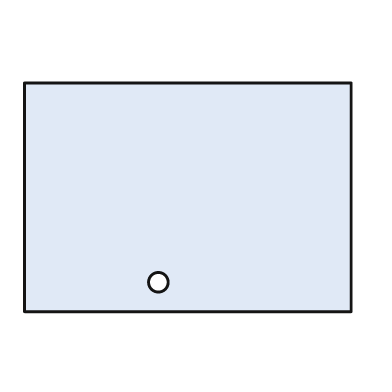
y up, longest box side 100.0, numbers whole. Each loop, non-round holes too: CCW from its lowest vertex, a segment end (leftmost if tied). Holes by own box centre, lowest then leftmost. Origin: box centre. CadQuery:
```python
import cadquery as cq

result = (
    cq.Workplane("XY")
    .moveTo(-50.0, -35.0)
    .lineTo(50.0, -35.0)
    .lineTo(50.0, 35.0)
    .lineTo(-50.0, 35.0)
    .close()
    .moveTo(-9.0, -26.0)
    .circle(3.0)
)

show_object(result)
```